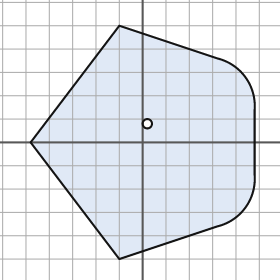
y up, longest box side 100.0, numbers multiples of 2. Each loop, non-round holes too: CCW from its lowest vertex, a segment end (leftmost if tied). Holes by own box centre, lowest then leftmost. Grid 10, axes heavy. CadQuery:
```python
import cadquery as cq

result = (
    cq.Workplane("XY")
    .moveTo(-10.0, -50.0)
    .lineTo(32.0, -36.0)
    .threePointArc((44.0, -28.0), (48.0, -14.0))
    .lineTo(48.0, 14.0)
    .threePointArc((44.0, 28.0), (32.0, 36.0))
    .lineTo(-10.0, 50.0)
    .lineTo(-48.0, 0.0)
    .close()
    .moveTo(2.0, 8.0)
    .circle(2.0)
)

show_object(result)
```